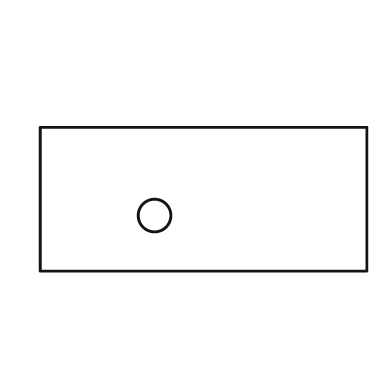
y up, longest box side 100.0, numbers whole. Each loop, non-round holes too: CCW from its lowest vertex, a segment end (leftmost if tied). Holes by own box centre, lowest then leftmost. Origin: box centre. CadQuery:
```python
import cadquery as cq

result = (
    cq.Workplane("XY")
    .moveTo(-50.0, -22.0)
    .lineTo(50.0, -22.0)
    .lineTo(50.0, 22.0)
    .lineTo(-50.0, 22.0)
    .close()
    .moveTo(-15.0, -5.0)
    .circle(5.0)
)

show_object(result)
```